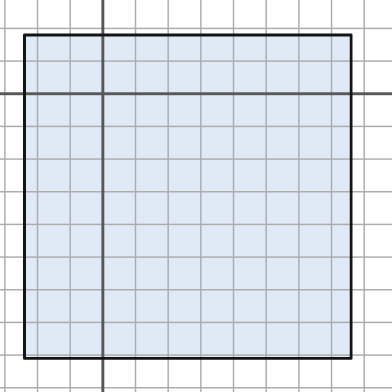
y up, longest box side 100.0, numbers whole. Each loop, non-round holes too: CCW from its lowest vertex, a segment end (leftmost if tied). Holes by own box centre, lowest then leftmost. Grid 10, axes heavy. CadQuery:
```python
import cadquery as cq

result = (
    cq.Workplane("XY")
    .moveTo(-24.0, -81.0)
    .lineTo(76.0, -81.0)
    .lineTo(76.0, 18.0)
    .lineTo(-24.0, 18.0)
    .close()
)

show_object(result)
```